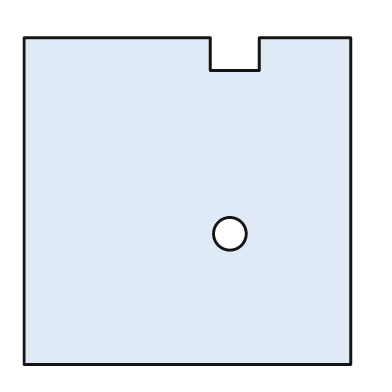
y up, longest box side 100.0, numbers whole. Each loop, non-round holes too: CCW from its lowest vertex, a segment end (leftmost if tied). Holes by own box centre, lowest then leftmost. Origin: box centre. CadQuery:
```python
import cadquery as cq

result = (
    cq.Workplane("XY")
    .moveTo(-50.0, -50.0)
    .lineTo(50.0, -50.0)
    .lineTo(50.0, 50.0)
    .lineTo(22.0, 50.0)
    .lineTo(22.0, 40.0)
    .lineTo(7.0, 40.0)
    .lineTo(7.0, 50.0)
    .lineTo(-50.0, 50.0)
    .close()
    .moveTo(13.0, -10.0)
    .circle(5.0)
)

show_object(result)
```